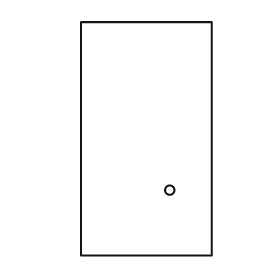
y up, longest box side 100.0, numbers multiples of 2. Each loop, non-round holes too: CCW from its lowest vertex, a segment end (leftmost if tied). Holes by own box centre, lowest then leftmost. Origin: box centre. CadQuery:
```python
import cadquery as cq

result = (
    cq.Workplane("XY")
    .moveTo(-28.0, -50.0)
    .lineTo(28.0, -50.0)
    .lineTo(28.0, 50.0)
    .lineTo(-28.0, 50.0)
    .close()
    .moveTo(10.0, -22.0)
    .circle(2.0)
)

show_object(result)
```